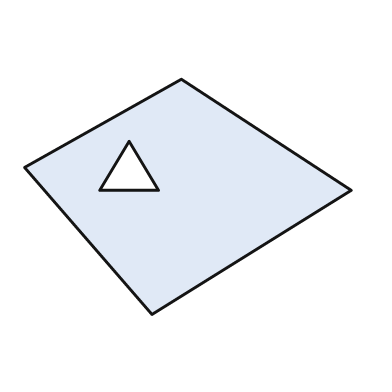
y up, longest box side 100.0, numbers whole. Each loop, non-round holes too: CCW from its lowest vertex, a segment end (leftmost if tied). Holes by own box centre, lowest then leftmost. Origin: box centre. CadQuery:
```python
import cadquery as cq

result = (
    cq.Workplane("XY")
    .moveTo(-11.0, -36.0)
    .lineTo(50.0, 2.0)
    .lineTo(-2.0, 36.0)
    .lineTo(-50.0, 9.0)
    .close()
    .moveTo(-27.0, 2.0)
    .lineTo(-9.0, 2.0)
    .lineTo(-18.0, 17.0)
    .close()
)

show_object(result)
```